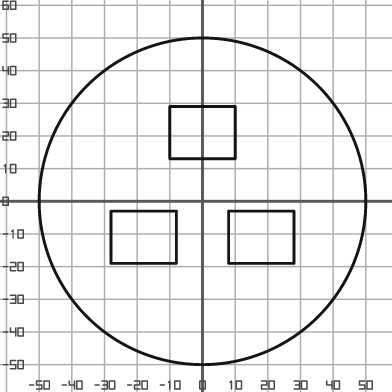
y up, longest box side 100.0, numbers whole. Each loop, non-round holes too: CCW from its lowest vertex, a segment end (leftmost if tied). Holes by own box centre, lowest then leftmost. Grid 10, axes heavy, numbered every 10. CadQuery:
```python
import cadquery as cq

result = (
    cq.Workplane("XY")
    .moveTo(0.0, 0.0)
    .circle(50.0)
    .moveTo(-28.0, -19.0)
    .lineTo(-8.0, -19.0)
    .lineTo(-8.0, -3.0)
    .lineTo(-28.0, -3.0)
    .close()
    .moveTo(8.0, -19.0)
    .lineTo(28.0, -19.0)
    .lineTo(28.0, -3.0)
    .lineTo(8.0, -3.0)
    .close()
    .moveTo(-10.0, 13.0)
    .lineTo(10.0, 13.0)
    .lineTo(10.0, 29.0)
    .lineTo(-10.0, 29.0)
    .close()
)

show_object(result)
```